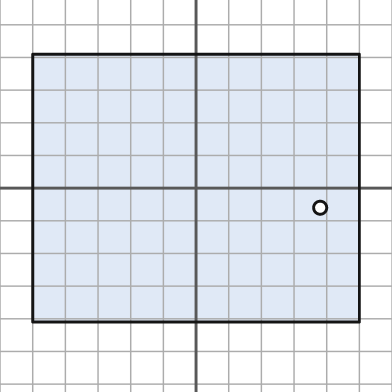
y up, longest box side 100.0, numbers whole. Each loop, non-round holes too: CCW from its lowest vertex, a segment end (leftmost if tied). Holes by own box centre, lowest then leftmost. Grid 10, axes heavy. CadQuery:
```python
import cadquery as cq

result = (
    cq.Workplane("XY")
    .moveTo(-50.0, -41.0)
    .lineTo(50.0, -41.0)
    .lineTo(50.0, 41.0)
    .lineTo(-50.0, 41.0)
    .close()
    .moveTo(38.0, -6.0)
    .circle(2.0)
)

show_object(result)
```